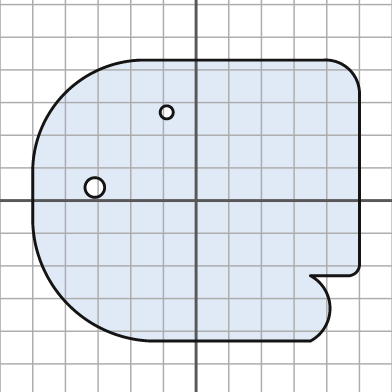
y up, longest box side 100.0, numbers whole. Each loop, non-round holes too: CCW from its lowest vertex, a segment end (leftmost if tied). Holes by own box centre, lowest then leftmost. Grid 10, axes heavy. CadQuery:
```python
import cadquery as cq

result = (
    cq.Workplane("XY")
    .moveTo(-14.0, -43.0)
    .lineTo(35.0, -43.0)
    .threePointArc((41.0, -33.0), (35.0, -23.0))
    .lineTo(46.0, -23.0)
    .threePointArc((49.0, -22.0), (50.0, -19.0))
    .lineTo(50.0, 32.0)
    .threePointArc((47.0, 40.0), (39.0, 43.0))
    .lineTo(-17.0, 43.0)
    .threePointArc((-40.0, 33.0), (-50.0, 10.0))
    .lineTo(-50.0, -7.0)
    .threePointArc((-39.0, -32.0), (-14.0, -43.0))
    .close()
    .moveTo(-31.0, 4.0)
    .circle(3.0)
    .moveTo(-9.0, 27.0)
    .circle(2.0)
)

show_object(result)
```